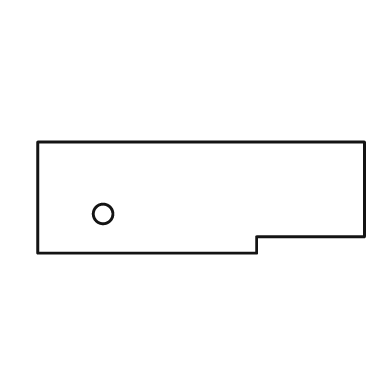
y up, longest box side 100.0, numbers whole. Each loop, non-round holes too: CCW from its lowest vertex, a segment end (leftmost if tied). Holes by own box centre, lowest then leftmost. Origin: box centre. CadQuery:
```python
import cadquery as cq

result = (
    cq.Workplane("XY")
    .moveTo(-50.0, -17.0)
    .lineTo(17.0, -17.0)
    .lineTo(17.0, -12.0)
    .lineTo(50.0, -12.0)
    .lineTo(50.0, 17.0)
    .lineTo(-50.0, 17.0)
    .close()
    .moveTo(-30.0, -5.0)
    .circle(3.0)
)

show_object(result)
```